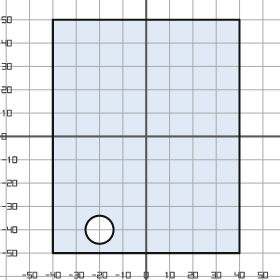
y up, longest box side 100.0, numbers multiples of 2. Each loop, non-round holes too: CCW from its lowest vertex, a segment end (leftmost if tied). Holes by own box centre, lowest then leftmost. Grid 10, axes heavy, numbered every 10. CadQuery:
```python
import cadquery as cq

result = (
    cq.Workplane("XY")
    .moveTo(-40.0, -50.0)
    .lineTo(40.0, -50.0)
    .lineTo(40.0, 50.0)
    .lineTo(-40.0, 50.0)
    .close()
    .moveTo(-20.0, -40.0)
    .circle(6.0)
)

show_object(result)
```